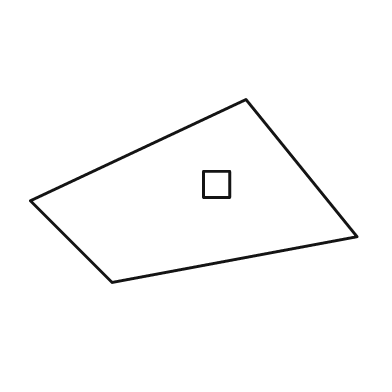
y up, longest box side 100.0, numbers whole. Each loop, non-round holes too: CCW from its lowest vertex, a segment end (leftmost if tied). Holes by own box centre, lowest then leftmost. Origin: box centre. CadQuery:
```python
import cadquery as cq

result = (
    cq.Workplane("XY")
    .moveTo(-25.0, -28.0)
    .lineTo(50.0, -14.0)
    .lineTo(16.0, 28.0)
    .lineTo(-50.0, -3.0)
    .close()
    .moveTo(3.0, -2.0)
    .lineTo(11.0, -2.0)
    .lineTo(11.0, 6.0)
    .lineTo(3.0, 6.0)
    .close()
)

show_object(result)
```